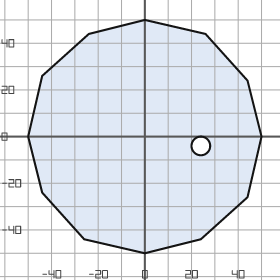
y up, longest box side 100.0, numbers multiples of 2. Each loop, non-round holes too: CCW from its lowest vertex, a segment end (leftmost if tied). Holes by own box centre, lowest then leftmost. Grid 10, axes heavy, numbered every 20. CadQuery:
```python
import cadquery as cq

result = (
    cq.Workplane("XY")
    .moveTo(0.0, -50.0)
    .lineTo(24.0, -44.0)
    .lineTo(44.0, -26.0)
    .lineTo(50.0, 0.0)
    .lineTo(44.0, 24.0)
    .lineTo(26.0, 44.0)
    .lineTo(0.0, 50.0)
    .lineTo(-24.0, 44.0)
    .lineTo(-44.0, 26.0)
    .lineTo(-50.0, 0.0)
    .lineTo(-44.0, -24.0)
    .lineTo(-26.0, -44.0)
    .close()
    .moveTo(24.0, -4.0)
    .circle(4.0)
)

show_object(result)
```